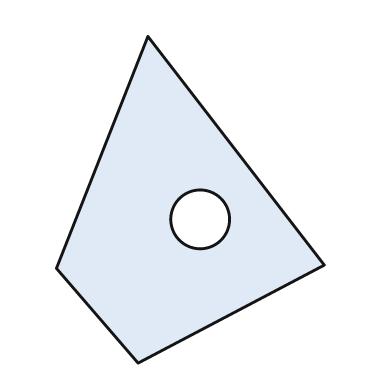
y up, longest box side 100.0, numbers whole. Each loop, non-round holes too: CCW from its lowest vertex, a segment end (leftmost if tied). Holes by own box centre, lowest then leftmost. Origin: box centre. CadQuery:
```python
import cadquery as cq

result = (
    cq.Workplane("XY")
    .moveTo(-16.0, -50.0)
    .lineTo(41.0, -20.0)
    .lineTo(-13.0, 50.0)
    .lineTo(-41.0, -21.0)
    .close()
    .moveTo(3.0, -6.0)
    .circle(9.0)
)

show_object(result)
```